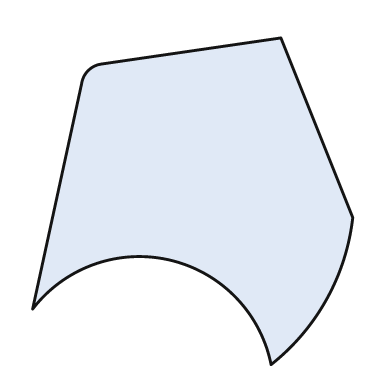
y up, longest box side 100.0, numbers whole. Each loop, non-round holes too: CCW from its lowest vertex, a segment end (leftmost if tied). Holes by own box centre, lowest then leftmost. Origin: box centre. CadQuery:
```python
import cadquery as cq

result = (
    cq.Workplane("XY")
    .moveTo(24.0, -50.0)
    .threePointArc((41.0, -30.0), (49.0, -5.0))
    .lineTo(27.0, 50.0)
    .lineTo(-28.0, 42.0)
    .threePointArc((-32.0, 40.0), (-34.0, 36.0))
    .lineTo(-49.0, -33.0)
    .threePointArc((-7.0, -18.0), (24.0, -50.0))
    .close()
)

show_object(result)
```